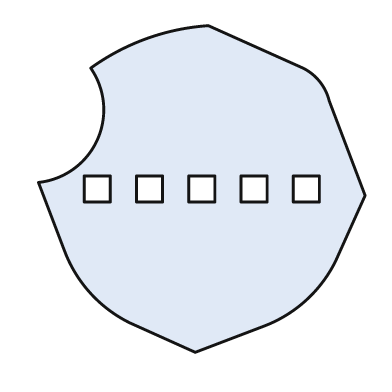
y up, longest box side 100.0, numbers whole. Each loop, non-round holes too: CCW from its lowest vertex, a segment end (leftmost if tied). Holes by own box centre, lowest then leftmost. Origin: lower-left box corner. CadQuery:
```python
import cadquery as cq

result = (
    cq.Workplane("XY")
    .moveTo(48.0, 0.0)
    .lineTo(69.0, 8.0)
    .threePointArc((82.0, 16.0), (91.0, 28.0))
    .lineTo(100.0, 48.0)
    .lineTo(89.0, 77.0)
    .threePointArc((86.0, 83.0), (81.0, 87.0))
    .lineTo(52.0, 100.0)
    .threePointArc((33.0, 96.0), (16.0, 87.0))
    .threePointArc((18.0, 65.0), (0.0, 52.0))
    .lineTo(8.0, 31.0)
    .threePointArc((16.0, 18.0), (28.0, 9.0))
    .close()
    .moveTo(14.0, 46.0)
    .lineTo(22.0, 46.0)
    .lineTo(22.0, 54.0)
    .lineTo(14.0, 54.0)
    .close()
    .moveTo(30.0, 46.0)
    .lineTo(38.0, 46.0)
    .lineTo(38.0, 54.0)
    .lineTo(30.0, 54.0)
    .close()
    .moveTo(46.0, 46.0)
    .lineTo(54.0, 46.0)
    .lineTo(54.0, 54.0)
    .lineTo(46.0, 54.0)
    .close()
    .moveTo(62.0, 46.0)
    .lineTo(70.0, 46.0)
    .lineTo(70.0, 54.0)
    .lineTo(62.0, 54.0)
    .close()
    .moveTo(78.0, 46.0)
    .lineTo(86.0, 46.0)
    .lineTo(86.0, 54.0)
    .lineTo(78.0, 54.0)
    .close()
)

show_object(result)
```